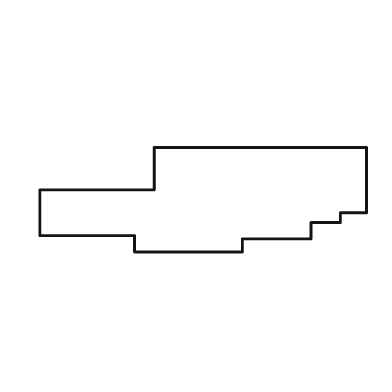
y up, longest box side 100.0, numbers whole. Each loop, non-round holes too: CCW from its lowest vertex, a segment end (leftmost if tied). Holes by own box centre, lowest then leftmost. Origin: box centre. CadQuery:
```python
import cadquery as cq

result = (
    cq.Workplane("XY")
    .moveTo(-21.0, -16.0)
    .lineTo(12.0, -16.0)
    .lineTo(12.0, -12.0)
    .lineTo(33.0, -12.0)
    .lineTo(33.0, -7.0)
    .lineTo(42.0, -7.0)
    .lineTo(42.0, -4.0)
    .lineTo(50.0, -4.0)
    .lineTo(50.0, 16.0)
    .lineTo(-15.0, 16.0)
    .lineTo(-15.0, 3.0)
    .lineTo(-50.0, 3.0)
    .lineTo(-50.0, -11.0)
    .lineTo(-21.0, -11.0)
    .close()
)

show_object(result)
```